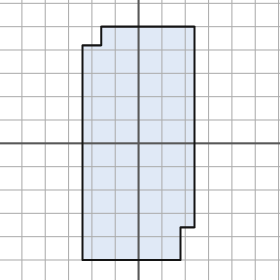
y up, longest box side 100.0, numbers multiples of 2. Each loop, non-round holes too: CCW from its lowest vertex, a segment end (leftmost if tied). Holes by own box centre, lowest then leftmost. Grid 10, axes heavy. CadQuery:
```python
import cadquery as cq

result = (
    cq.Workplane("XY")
    .moveTo(-24.0, -50.0)
    .lineTo(18.0, -50.0)
    .lineTo(18.0, -36.0)
    .lineTo(24.0, -36.0)
    .lineTo(24.0, 50.0)
    .lineTo(-16.0, 50.0)
    .lineTo(-16.0, 42.0)
    .lineTo(-24.0, 42.0)
    .close()
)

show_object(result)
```